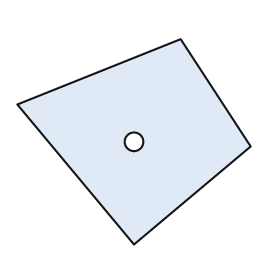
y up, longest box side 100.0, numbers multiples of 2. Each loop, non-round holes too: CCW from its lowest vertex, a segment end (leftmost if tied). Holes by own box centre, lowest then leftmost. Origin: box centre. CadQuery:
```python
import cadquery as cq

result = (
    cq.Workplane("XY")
    .moveTo(0.0, -44.0)
    .lineTo(50.0, -2.0)
    .lineTo(20.0, 44.0)
    .lineTo(-50.0, 16.0)
    .close()
    .moveTo(0.0, 0.0)
    .circle(4.0)
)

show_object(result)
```